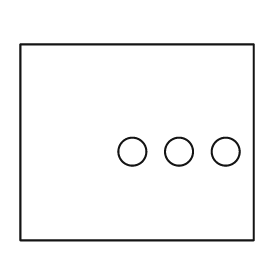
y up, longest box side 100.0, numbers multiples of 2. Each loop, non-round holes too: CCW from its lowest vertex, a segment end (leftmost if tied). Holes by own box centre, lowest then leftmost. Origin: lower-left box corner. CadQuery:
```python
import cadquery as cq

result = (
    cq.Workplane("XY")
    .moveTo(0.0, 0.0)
    .lineTo(100.0, 0.0)
    .lineTo(100.0, 84.0)
    .lineTo(0.0, 84.0)
    .close()
    .moveTo(48.0, 38.0)
    .circle(6.0)
    .moveTo(68.0, 38.0)
    .circle(6.0)
    .moveTo(88.0, 38.0)
    .circle(6.0)
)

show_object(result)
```